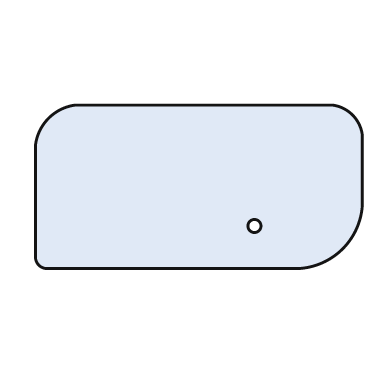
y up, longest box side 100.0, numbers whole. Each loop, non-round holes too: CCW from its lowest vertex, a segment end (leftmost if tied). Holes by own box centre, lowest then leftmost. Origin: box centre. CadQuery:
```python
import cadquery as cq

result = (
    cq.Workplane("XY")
    .moveTo(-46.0, -25.0)
    .lineTo(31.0, -25.0)
    .threePointArc((44.0, -19.0), (50.0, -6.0))
    .lineTo(50.0, 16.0)
    .threePointArc((47.0, 22.0), (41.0, 25.0))
    .lineTo(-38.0, 25.0)
    .threePointArc((-46.0, 21.0), (-50.0, 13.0))
    .lineTo(-50.0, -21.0)
    .threePointArc((-49.0, -24.0), (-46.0, -25.0))
    .close()
    .moveTo(17.0, -12.0)
    .circle(2.0)
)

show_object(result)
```